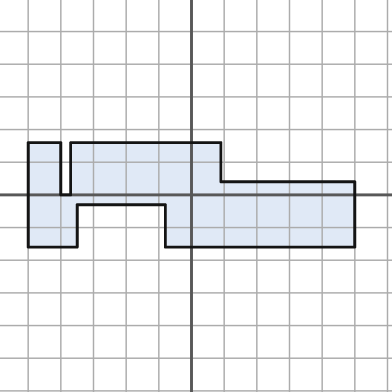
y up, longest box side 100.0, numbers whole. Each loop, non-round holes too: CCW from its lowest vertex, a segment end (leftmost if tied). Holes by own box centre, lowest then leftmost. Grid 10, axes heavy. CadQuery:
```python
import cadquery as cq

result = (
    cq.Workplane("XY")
    .moveTo(-50.0, -16.0)
    .lineTo(-35.0, -16.0)
    .lineTo(-35.0, -3.0)
    .lineTo(-8.0, -3.0)
    .lineTo(-8.0, -16.0)
    .lineTo(50.0, -16.0)
    .lineTo(50.0, 4.0)
    .lineTo(9.0, 4.0)
    .lineTo(9.0, 16.0)
    .lineTo(-37.0, 16.0)
    .lineTo(-37.0, 0.0)
    .lineTo(-40.0, 0.0)
    .lineTo(-40.0, 16.0)
    .lineTo(-50.0, 16.0)
    .close()
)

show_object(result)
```